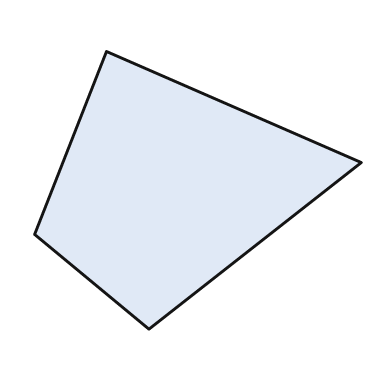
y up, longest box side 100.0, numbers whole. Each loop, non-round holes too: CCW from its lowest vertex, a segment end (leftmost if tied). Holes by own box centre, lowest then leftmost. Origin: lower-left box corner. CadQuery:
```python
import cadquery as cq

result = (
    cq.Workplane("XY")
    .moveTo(35.0, 0.0)
    .lineTo(100.0, 51.0)
    .lineTo(22.0, 85.0)
    .lineTo(0.0, 29.0)
    .close()
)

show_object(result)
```